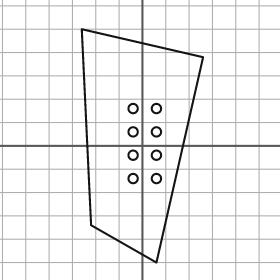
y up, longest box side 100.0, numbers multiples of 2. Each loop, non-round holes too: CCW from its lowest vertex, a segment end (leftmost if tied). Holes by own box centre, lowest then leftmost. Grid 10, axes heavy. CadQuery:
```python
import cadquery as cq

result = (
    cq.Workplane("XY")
    .moveTo(6.0, -50.0)
    .lineTo(26.0, 38.0)
    .lineTo(-26.0, 50.0)
    .lineTo(-22.0, -34.0)
    .close()
    .moveTo(-4.0, -14.0)
    .circle(2.0)
    .moveTo(6.0, -14.0)
    .circle(2.0)
    .moveTo(-4.0, -4.0)
    .circle(2.0)
    .moveTo(6.0, -4.0)
    .circle(2.0)
    .moveTo(-4.0, 6.0)
    .circle(2.0)
    .moveTo(6.0, 6.0)
    .circle(2.0)
    .moveTo(-4.0, 16.0)
    .circle(2.0)
    .moveTo(6.0, 16.0)
    .circle(2.0)
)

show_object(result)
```